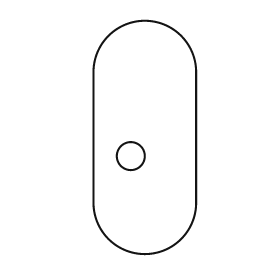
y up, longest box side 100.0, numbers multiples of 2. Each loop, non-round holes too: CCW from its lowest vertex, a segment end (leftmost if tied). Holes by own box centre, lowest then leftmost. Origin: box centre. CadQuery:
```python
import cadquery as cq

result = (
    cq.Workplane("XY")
    .moveTo(-22.0, -28.0)
    .threePointArc((0.0, -50.0), (22.0, -28.0))
    .lineTo(22.0, 28.0)
    .threePointArc((0.0, 50.0), (-22.0, 28.0))
    .close()
    .moveTo(-6.0, -8.0)
    .circle(6.0)
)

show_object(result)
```